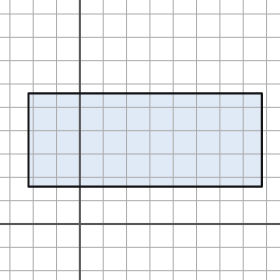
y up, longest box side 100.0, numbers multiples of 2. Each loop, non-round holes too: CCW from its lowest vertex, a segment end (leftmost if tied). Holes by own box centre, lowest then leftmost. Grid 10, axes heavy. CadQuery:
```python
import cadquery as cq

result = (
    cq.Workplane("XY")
    .moveTo(-22.0, 16.0)
    .lineTo(78.0, 16.0)
    .lineTo(78.0, 56.0)
    .lineTo(-22.0, 56.0)
    .close()
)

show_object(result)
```